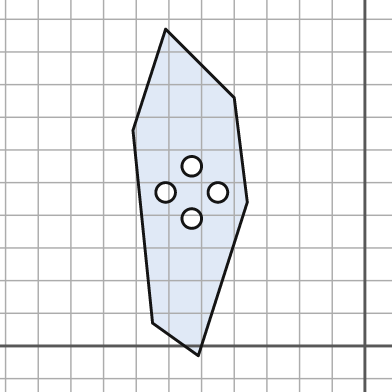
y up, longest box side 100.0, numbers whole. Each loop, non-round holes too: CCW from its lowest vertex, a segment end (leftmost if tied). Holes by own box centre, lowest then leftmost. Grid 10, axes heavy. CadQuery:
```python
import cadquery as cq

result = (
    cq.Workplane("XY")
    .moveTo(-51.0, -3.0)
    .lineTo(-36.0, 44.0)
    .lineTo(-40.0, 76.0)
    .lineTo(-61.0, 97.0)
    .lineTo(-71.0, 66.0)
    .lineTo(-65.0, 7.0)
    .close()
    .moveTo(-53.0, 39.0)
    .circle(3.0)
    .moveTo(-61.0, 47.0)
    .circle(3.0)
    .moveTo(-45.0, 47.0)
    .circle(3.0)
    .moveTo(-53.0, 55.0)
    .circle(3.0)
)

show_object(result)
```